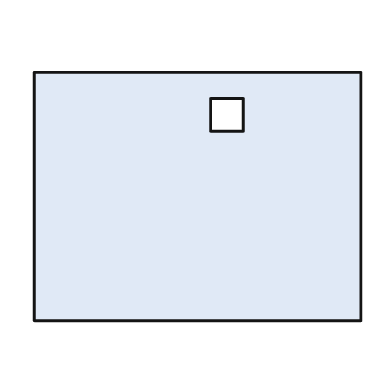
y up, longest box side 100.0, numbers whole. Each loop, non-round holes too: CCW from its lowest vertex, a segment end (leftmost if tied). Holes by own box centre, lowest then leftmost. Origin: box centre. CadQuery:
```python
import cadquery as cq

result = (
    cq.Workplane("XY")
    .moveTo(-50.0, -38.0)
    .lineTo(50.0, -38.0)
    .lineTo(50.0, 38.0)
    .lineTo(-50.0, 38.0)
    .close()
    .moveTo(4.0, 20.0)
    .lineTo(14.0, 20.0)
    .lineTo(14.0, 30.0)
    .lineTo(4.0, 30.0)
    .close()
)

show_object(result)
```